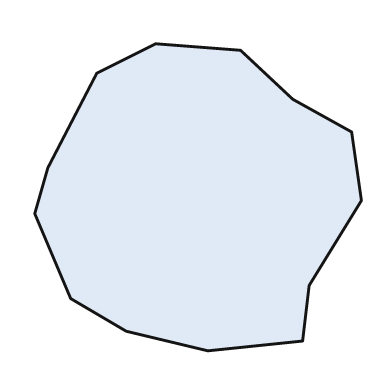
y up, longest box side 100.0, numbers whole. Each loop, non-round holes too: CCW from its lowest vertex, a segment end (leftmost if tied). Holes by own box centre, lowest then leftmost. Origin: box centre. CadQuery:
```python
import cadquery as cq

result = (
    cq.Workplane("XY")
    .moveTo(3.0, -47.0)
    .lineTo(32.0, -44.0)
    .lineTo(34.0, -27.0)
    .lineTo(50.0, -1.0)
    .lineTo(47.0, 20.0)
    .lineTo(29.0, 30.0)
    .lineTo(13.0, 45.0)
    .lineTo(-13.0, 47.0)
    .lineTo(-31.0, 38.0)
    .lineTo(-46.0, 9.0)
    .lineTo(-50.0, -5.0)
    .lineTo(-39.0, -31.0)
    .lineTo(-22.0, -41.0)
    .close()
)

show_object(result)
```